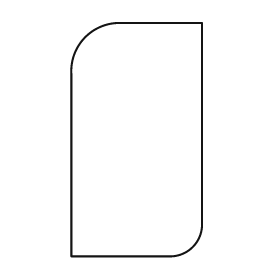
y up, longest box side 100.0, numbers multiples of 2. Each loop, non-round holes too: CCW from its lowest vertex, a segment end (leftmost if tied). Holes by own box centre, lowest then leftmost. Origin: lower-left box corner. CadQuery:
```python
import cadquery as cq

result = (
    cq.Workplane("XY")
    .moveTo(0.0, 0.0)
    .lineTo(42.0, 0.0)
    .threePointArc((52.0, 4.0), (56.0, 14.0))
    .lineTo(56.0, 100.0)
    .lineTo(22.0, 100.0)
    .threePointArc((6.0, 94.0), (0.0, 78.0))
    .close()
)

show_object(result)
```